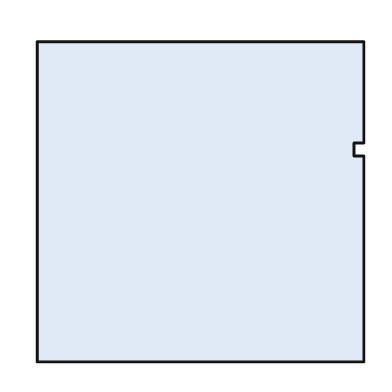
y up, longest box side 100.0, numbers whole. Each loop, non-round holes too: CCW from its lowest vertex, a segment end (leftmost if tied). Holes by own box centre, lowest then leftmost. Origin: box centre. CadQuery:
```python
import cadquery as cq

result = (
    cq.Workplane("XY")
    .moveTo(-50.0, -49.0)
    .lineTo(50.0, -49.0)
    .lineTo(50.0, 14.0)
    .lineTo(47.0, 14.0)
    .lineTo(47.0, 18.0)
    .lineTo(50.0, 18.0)
    .lineTo(50.0, 49.0)
    .lineTo(-50.0, 49.0)
    .close()
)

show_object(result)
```